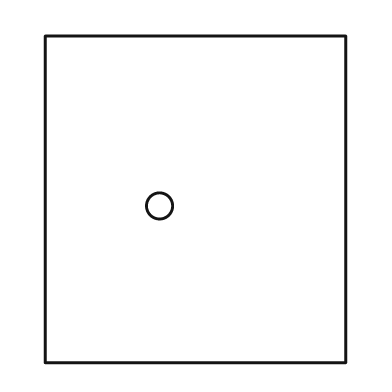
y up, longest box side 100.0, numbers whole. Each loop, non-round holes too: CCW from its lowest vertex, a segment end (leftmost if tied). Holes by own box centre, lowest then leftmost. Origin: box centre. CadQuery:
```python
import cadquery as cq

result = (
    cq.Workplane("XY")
    .moveTo(-46.0, -50.0)
    .lineTo(46.0, -50.0)
    .lineTo(46.0, 50.0)
    .lineTo(-46.0, 50.0)
    .close()
    .moveTo(-11.0, -2.0)
    .circle(4.0)
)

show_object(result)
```